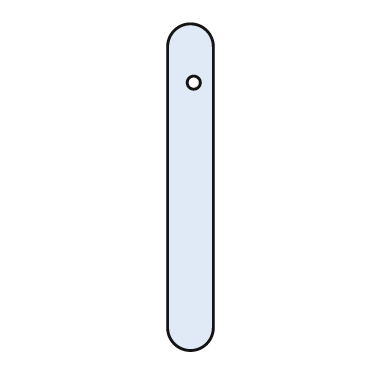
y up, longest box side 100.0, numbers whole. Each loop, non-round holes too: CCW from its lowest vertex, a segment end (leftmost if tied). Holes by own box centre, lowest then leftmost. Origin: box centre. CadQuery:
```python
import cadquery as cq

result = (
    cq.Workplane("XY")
    .moveTo(-7.0, -43.0)
    .threePointArc((0.0, -50.0), (7.0, -43.0))
    .lineTo(7.0, 43.0)
    .threePointArc((0.0, 50.0), (-7.0, 43.0))
    .close()
    .moveTo(1.0, 32.0)
    .circle(2.0)
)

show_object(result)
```